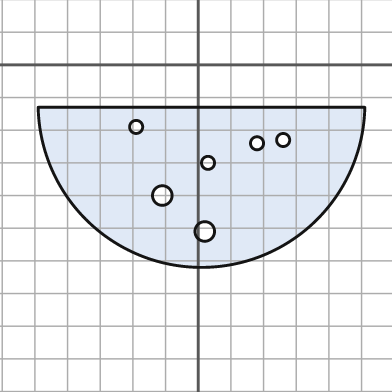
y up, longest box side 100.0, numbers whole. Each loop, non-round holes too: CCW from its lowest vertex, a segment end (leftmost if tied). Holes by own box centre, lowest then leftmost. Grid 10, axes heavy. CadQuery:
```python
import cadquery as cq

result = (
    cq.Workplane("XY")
    .moveTo(-49.0, -13.0)
    .threePointArc((1.0, -62.0), (51.0, -13.0))
    .close()
    .moveTo(2.0, -51.0)
    .circle(3.0)
    .moveTo(-11.0, -40.0)
    .circle(3.0)
    .moveTo(3.0, -30.0)
    .circle(2.0)
    .moveTo(18.0, -24.0)
    .circle(2.0)
    .moveTo(26.0, -23.0)
    .circle(2.0)
    .moveTo(-19.0, -19.0)
    .circle(2.0)
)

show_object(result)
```